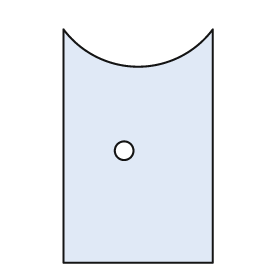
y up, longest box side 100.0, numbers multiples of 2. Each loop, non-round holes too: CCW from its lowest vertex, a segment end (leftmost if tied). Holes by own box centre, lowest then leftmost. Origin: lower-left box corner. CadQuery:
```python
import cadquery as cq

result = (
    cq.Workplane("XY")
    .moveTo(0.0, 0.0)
    .lineTo(64.0, 0.0)
    .lineTo(64.0, 100.0)
    .threePointArc((32.0, 84.0), (0.0, 100.0))
    .close()
    .moveTo(26.0, 48.0)
    .circle(4.0)
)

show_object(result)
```